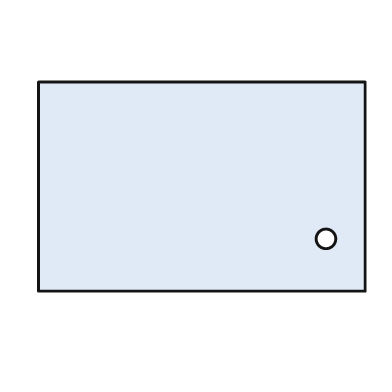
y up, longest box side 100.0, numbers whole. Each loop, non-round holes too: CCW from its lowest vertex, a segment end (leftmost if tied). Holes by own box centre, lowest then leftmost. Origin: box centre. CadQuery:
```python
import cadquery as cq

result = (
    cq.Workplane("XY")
    .moveTo(-50.0, -32.0)
    .lineTo(50.0, -32.0)
    .lineTo(50.0, 32.0)
    .lineTo(-50.0, 32.0)
    .close()
    .moveTo(38.0, -16.0)
    .circle(3.0)
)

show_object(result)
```